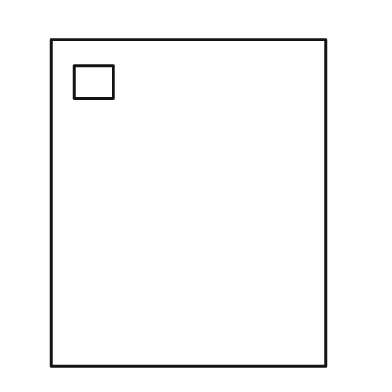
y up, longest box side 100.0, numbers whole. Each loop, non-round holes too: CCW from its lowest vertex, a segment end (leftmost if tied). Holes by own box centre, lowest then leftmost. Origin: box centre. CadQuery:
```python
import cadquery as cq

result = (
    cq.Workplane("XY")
    .moveTo(-42.0, -50.0)
    .lineTo(42.0, -50.0)
    .lineTo(42.0, 50.0)
    .lineTo(-42.0, 50.0)
    .close()
    .moveTo(-35.0, 32.0)
    .lineTo(-23.0, 32.0)
    .lineTo(-23.0, 42.0)
    .lineTo(-35.0, 42.0)
    .close()
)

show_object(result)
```